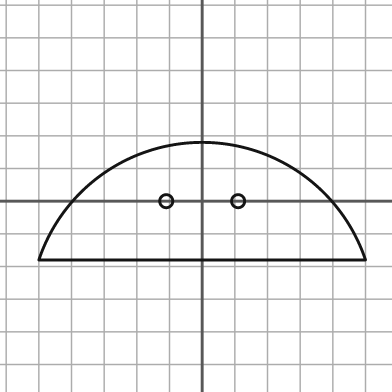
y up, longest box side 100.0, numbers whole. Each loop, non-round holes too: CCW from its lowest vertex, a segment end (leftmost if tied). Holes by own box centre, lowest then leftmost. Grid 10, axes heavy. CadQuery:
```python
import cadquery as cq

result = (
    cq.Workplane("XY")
    .moveTo(-50.0, -18.0)
    .lineTo(50.0, -18.0)
    .threePointArc((0.0, 18.0), (-50.0, -18.0))
    .close()
    .moveTo(-11.0, 0.0)
    .circle(2.0)
    .moveTo(11.0, 0.0)
    .circle(2.0)
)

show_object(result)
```